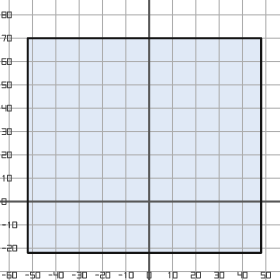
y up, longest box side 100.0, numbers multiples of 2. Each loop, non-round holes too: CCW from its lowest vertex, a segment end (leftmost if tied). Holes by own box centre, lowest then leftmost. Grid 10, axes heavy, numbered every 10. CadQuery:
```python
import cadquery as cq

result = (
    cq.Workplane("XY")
    .moveTo(-52.0, -22.0)
    .lineTo(48.0, -22.0)
    .lineTo(48.0, 70.0)
    .lineTo(-52.0, 70.0)
    .close()
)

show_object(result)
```